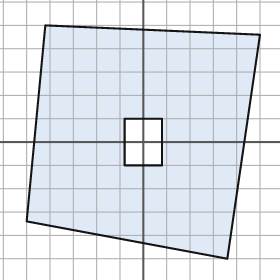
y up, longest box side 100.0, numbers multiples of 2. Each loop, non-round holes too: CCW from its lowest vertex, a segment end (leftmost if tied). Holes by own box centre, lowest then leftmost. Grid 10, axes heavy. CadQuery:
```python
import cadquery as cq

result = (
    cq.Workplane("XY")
    .moveTo(36.0, -50.0)
    .lineTo(50.0, 46.0)
    .lineTo(-42.0, 50.0)
    .lineTo(-50.0, -34.0)
    .close()
    .moveTo(-8.0, -10.0)
    .lineTo(8.0, -10.0)
    .lineTo(8.0, 10.0)
    .lineTo(-8.0, 10.0)
    .close()
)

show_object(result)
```